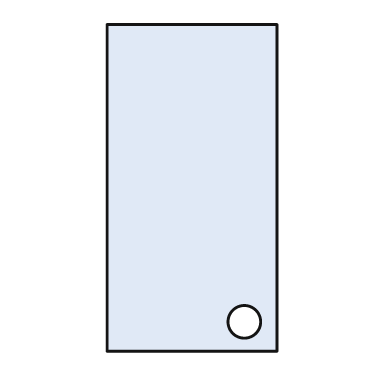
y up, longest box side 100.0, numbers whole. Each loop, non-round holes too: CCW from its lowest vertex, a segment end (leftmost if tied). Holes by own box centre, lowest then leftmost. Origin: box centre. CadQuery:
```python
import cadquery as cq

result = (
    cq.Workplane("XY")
    .moveTo(-26.0, -50.0)
    .lineTo(26.0, -50.0)
    .lineTo(26.0, 50.0)
    .lineTo(-26.0, 50.0)
    .close()
    .moveTo(16.0, -41.0)
    .circle(5.0)
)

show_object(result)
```